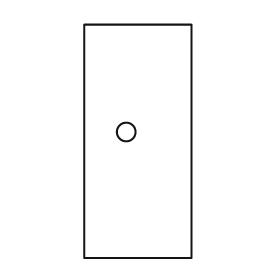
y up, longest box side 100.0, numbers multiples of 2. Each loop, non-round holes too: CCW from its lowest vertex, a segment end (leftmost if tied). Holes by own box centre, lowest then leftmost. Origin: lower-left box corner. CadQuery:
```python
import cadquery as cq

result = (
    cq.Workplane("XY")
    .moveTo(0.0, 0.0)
    .lineTo(46.0, 0.0)
    .lineTo(46.0, 100.0)
    .lineTo(0.0, 100.0)
    .close()
    .moveTo(18.0, 54.0)
    .circle(4.0)
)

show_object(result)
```